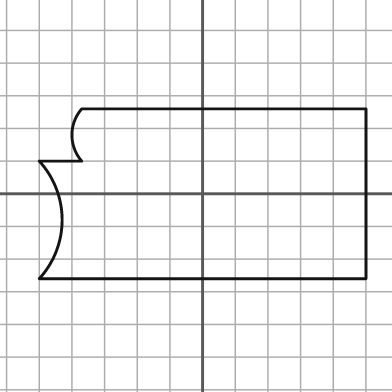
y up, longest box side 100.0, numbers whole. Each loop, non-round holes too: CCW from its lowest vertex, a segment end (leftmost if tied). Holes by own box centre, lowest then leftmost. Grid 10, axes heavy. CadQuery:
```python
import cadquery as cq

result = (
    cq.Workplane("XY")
    .moveTo(-50.0, -26.0)
    .lineTo(50.0, -26.0)
    .lineTo(50.0, 26.0)
    .lineTo(-37.0, 26.0)
    .threePointArc((-40.0, 18.0), (-37.0, 10.0))
    .lineTo(-50.0, 10.0)
    .threePointArc((-43.0, -8.0), (-50.0, -26.0))
    .close()
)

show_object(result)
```